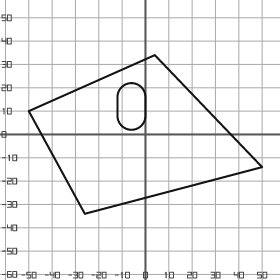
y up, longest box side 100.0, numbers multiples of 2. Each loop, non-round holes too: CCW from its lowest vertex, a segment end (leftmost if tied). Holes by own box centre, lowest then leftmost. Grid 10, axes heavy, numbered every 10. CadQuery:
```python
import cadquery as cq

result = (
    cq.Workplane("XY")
    .moveTo(-26.0, -34.0)
    .lineTo(50.0, -14.0)
    .lineTo(4.0, 34.0)
    .lineTo(-50.0, 10.0)
    .close()
    .moveTo(-12.0, 8.0)
    .threePointArc((-6.0, 2.0), (0.0, 8.0))
    .lineTo(0.0, 16.0)
    .threePointArc((-6.0, 22.0), (-12.0, 16.0))
    .close()
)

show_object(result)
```